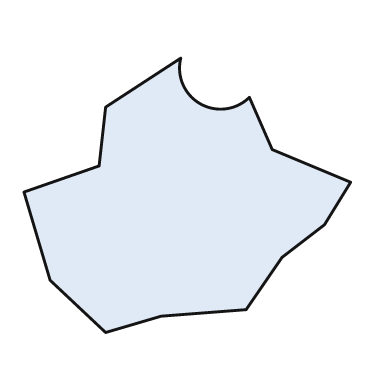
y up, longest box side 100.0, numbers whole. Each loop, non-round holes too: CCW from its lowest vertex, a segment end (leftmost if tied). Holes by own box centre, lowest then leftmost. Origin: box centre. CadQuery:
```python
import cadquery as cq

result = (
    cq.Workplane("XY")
    .moveTo(-25.0, -42.0)
    .lineTo(-8.0, -37.0)
    .lineTo(18.0, -35.0)
    .lineTo(29.0, -19.0)
    .lineTo(42.0, -9.0)
    .lineTo(50.0, 4.0)
    .lineTo(26.0, 14.0)
    .lineTo(19.0, 30.0)
    .threePointArc((4.0, 28.0), (-2.0, 42.0))
    .lineTo(-25.0, 27.0)
    .lineTo(-27.0, 9.0)
    .lineTo(-50.0, 1.0)
    .lineTo(-42.0, -26.0)
    .close()
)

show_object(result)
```